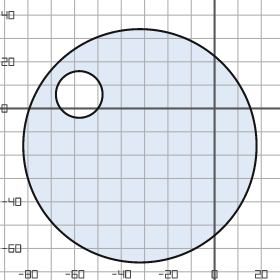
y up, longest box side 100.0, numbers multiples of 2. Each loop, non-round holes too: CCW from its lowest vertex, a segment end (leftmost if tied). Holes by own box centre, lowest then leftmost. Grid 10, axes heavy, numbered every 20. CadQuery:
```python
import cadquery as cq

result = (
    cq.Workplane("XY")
    .moveTo(-32.0, -16.0)
    .circle(50.0)
    .moveTo(-58.0, 6.0)
    .circle(10.0)
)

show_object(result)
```